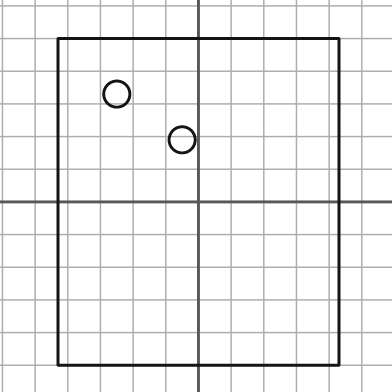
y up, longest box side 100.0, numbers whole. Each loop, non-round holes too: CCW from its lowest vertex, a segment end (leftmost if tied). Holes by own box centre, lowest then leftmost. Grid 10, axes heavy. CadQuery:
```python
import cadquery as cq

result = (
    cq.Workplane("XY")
    .moveTo(-43.0, -50.0)
    .lineTo(43.0, -50.0)
    .lineTo(43.0, 50.0)
    .lineTo(-43.0, 50.0)
    .close()
    .moveTo(-5.0, 19.0)
    .circle(4.0)
    .moveTo(-25.0, 33.0)
    .circle(4.0)
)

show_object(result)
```